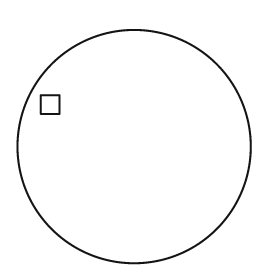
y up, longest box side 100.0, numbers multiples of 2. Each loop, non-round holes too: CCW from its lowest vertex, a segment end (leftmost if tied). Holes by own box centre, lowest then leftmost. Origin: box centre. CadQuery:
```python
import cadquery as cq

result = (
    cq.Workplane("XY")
    .moveTo(0.0, 0.0)
    .circle(50.0)
    .moveTo(-40.0, 14.0)
    .lineTo(-32.0, 14.0)
    .lineTo(-32.0, 22.0)
    .lineTo(-40.0, 22.0)
    .close()
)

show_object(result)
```